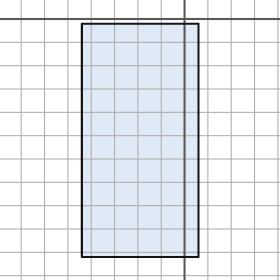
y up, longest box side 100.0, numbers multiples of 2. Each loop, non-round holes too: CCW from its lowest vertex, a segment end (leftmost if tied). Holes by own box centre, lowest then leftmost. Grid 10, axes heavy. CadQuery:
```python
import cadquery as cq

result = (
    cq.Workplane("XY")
    .moveTo(-44.0, -102.0)
    .lineTo(6.0, -102.0)
    .lineTo(6.0, -2.0)
    .lineTo(-44.0, -2.0)
    .close()
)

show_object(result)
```